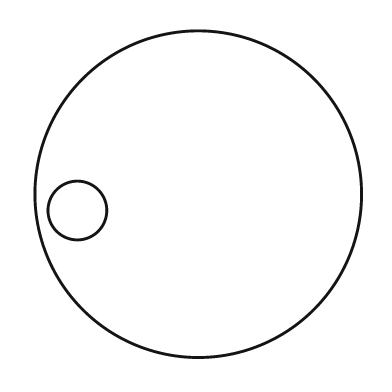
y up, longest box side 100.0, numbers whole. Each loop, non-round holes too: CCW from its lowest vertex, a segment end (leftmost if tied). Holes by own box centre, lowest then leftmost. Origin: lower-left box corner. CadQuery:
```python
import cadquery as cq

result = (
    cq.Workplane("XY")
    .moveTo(50.0, 50.0)
    .circle(50.0)
    .moveTo(13.0, 45.0)
    .circle(9.0)
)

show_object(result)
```